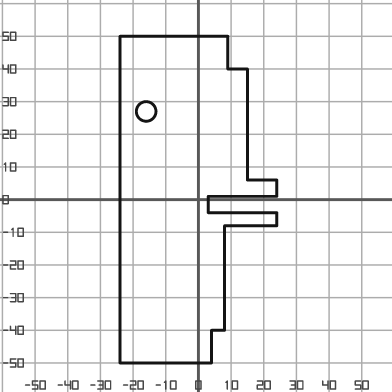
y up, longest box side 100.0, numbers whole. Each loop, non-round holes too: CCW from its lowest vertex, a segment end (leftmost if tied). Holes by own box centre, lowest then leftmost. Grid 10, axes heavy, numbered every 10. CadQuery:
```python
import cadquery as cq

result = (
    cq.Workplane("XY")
    .moveTo(-24.0, -50.0)
    .lineTo(4.0, -50.0)
    .lineTo(4.0, -40.0)
    .lineTo(8.0, -40.0)
    .lineTo(8.0, -8.0)
    .lineTo(24.0, -8.0)
    .lineTo(24.0, -4.0)
    .lineTo(3.0, -4.0)
    .lineTo(3.0, 1.0)
    .lineTo(24.0, 1.0)
    .lineTo(24.0, 6.0)
    .lineTo(15.0, 6.0)
    .lineTo(15.0, 40.0)
    .lineTo(9.0, 40.0)
    .lineTo(9.0, 50.0)
    .lineTo(-24.0, 50.0)
    .close()
    .moveTo(-16.0, 27.0)
    .circle(3.0)
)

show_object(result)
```